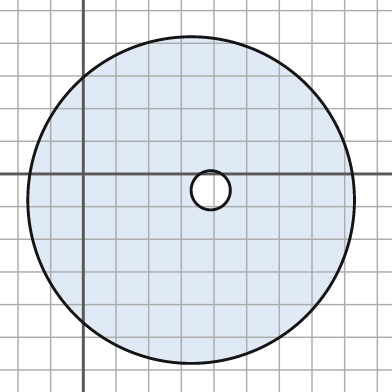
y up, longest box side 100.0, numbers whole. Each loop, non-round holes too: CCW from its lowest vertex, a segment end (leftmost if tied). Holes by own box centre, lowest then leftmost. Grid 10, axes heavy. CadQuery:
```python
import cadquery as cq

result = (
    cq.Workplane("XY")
    .moveTo(33.0, -8.0)
    .circle(50.0)
    .moveTo(39.0, -5.0)
    .circle(6.0)
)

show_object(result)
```